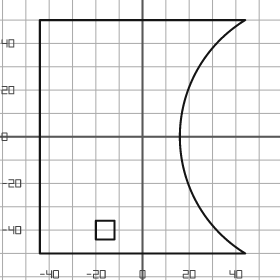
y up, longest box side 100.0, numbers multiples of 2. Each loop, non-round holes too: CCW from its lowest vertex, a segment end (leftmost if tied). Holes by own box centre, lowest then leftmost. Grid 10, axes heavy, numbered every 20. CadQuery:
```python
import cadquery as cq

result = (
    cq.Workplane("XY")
    .moveTo(-44.0, -50.0)
    .lineTo(44.0, -50.0)
    .threePointArc((16.0, 0.0), (44.0, 50.0))
    .lineTo(-44.0, 50.0)
    .close()
    .moveTo(-20.0, -44.0)
    .lineTo(-12.0, -44.0)
    .lineTo(-12.0, -36.0)
    .lineTo(-20.0, -36.0)
    .close()
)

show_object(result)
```